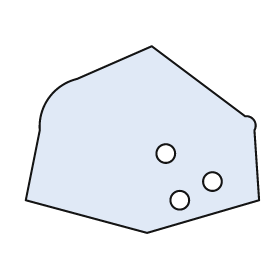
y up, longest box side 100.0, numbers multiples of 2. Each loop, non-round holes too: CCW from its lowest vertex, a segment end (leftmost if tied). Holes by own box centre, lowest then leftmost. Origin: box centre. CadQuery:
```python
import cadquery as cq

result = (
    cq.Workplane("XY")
    .moveTo(2.0, -40.0)
    .lineTo(50.0, -26.0)
    .lineTo(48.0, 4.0)
    .threePointArc((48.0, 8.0), (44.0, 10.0))
    .lineTo(4.0, 40.0)
    .lineTo(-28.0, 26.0)
    .threePointArc((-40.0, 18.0), (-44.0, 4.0))
    .lineTo(-50.0, -26.0)
    .close()
    .moveTo(16.0, -26.0)
    .circle(4.0)
    .moveTo(30.0, -18.0)
    .circle(4.0)
    .moveTo(10.0, -6.0)
    .circle(4.0)
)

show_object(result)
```